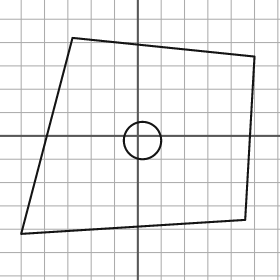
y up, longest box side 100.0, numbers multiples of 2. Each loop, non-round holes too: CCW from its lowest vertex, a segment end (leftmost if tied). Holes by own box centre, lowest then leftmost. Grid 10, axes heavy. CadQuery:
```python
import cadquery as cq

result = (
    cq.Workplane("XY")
    .moveTo(-50.0, -42.0)
    .lineTo(46.0, -36.0)
    .lineTo(50.0, 34.0)
    .lineTo(-28.0, 42.0)
    .close()
    .moveTo(2.0, -2.0)
    .circle(8.0)
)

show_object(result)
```